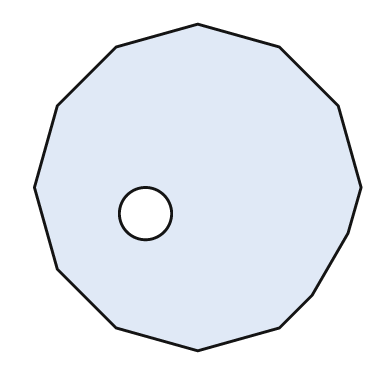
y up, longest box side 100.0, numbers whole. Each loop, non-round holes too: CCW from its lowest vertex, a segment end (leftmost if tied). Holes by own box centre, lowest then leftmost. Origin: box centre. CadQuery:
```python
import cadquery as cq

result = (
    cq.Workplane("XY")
    .moveTo(0.0, -50.0)
    .lineTo(25.0, -43.0)
    .lineTo(35.0, -33.0)
    .lineTo(46.0, -14.0)
    .lineTo(50.0, 0.0)
    .lineTo(43.0, 25.0)
    .lineTo(25.0, 43.0)
    .lineTo(0.0, 50.0)
    .lineTo(-25.0, 43.0)
    .lineTo(-43.0, 25.0)
    .lineTo(-50.0, 0.0)
    .lineTo(-43.0, -25.0)
    .lineTo(-25.0, -43.0)
    .close()
    .moveTo(-16.0, -8.0)
    .circle(8.0)
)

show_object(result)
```